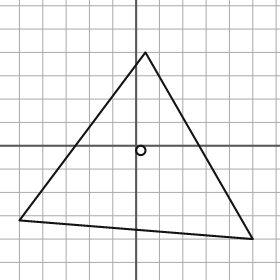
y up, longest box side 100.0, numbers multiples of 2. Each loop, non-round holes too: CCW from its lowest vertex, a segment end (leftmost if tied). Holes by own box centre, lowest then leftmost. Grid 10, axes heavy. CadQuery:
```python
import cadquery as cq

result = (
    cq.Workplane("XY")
    .moveTo(50.0, -40.0)
    .lineTo(4.0, 40.0)
    .lineTo(-50.0, -32.0)
    .close()
    .moveTo(2.0, -2.0)
    .circle(2.0)
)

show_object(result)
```